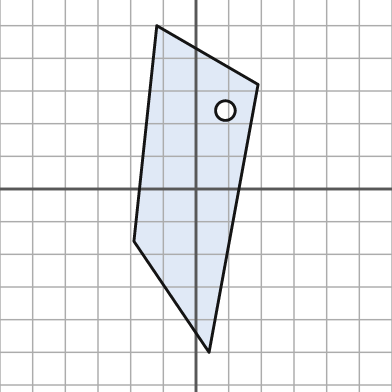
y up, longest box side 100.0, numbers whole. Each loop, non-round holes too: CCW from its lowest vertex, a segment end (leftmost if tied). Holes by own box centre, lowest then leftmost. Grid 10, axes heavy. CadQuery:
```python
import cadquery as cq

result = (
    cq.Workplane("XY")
    .moveTo(4.0, -50.0)
    .lineTo(19.0, 32.0)
    .lineTo(-12.0, 50.0)
    .lineTo(-19.0, -16.0)
    .close()
    .moveTo(9.0, 24.0)
    .circle(3.0)
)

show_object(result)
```